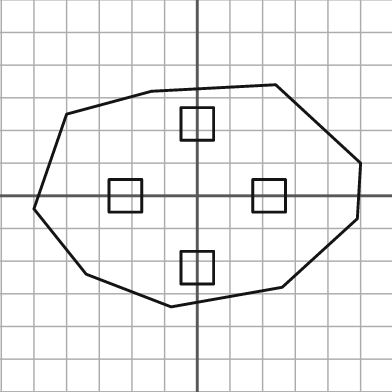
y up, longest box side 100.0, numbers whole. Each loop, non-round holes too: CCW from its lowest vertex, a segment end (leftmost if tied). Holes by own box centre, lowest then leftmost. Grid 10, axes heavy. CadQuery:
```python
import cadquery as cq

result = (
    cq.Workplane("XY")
    .moveTo(-8.0, -34.0)
    .lineTo(26.0, -28.0)
    .lineTo(49.0, -7.0)
    .lineTo(50.0, 10.0)
    .lineTo(24.0, 34.0)
    .lineTo(-14.0, 32.0)
    .lineTo(-40.0, 25.0)
    .lineTo(-50.0, -4.0)
    .lineTo(-34.0, -24.0)
    .close()
    .moveTo(-5.0, -27.0)
    .lineTo(5.0, -27.0)
    .lineTo(5.0, -17.0)
    .lineTo(-5.0, -17.0)
    .close()
    .moveTo(-27.0, -5.0)
    .lineTo(-17.0, -5.0)
    .lineTo(-17.0, 5.0)
    .lineTo(-27.0, 5.0)
    .close()
    .moveTo(17.0, -5.0)
    .lineTo(27.0, -5.0)
    .lineTo(27.0, 5.0)
    .lineTo(17.0, 5.0)
    .close()
    .moveTo(-5.0, 17.0)
    .lineTo(5.0, 17.0)
    .lineTo(5.0, 27.0)
    .lineTo(-5.0, 27.0)
    .close()
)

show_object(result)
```